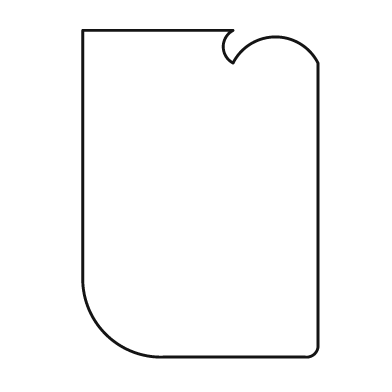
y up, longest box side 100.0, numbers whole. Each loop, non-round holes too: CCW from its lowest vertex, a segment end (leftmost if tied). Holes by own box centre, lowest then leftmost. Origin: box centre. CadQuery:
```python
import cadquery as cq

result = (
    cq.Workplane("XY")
    .moveTo(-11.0, -50.0)
    .lineTo(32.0, -50.0)
    .threePointArc((35.0, -49.0), (36.0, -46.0))
    .lineTo(36.0, 40.0)
    .threePointArc((23.0, 48.0), (10.0, 40.0))
    .threePointArc((7.0, 45.0), (10.0, 50.0))
    .lineTo(-36.0, 50.0)
    .lineTo(-36.0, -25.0)
    .threePointArc((-29.0, -43.0), (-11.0, -50.0))
    .close()
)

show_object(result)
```